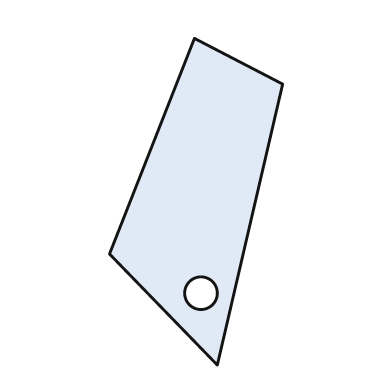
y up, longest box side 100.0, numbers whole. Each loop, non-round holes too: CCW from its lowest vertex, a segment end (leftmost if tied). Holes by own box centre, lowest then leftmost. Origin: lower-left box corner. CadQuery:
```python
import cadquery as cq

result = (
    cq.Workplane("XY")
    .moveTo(33.0, 0.0)
    .lineTo(53.0, 86.0)
    .lineTo(26.0, 100.0)
    .lineTo(0.0, 34.0)
    .close()
    .moveTo(28.0, 22.0)
    .circle(5.0)
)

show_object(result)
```